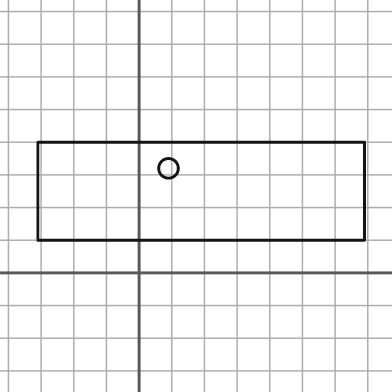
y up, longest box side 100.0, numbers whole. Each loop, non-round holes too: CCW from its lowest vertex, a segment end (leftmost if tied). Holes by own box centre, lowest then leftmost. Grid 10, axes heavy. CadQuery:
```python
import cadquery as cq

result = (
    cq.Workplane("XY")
    .moveTo(-31.0, 10.0)
    .lineTo(69.0, 10.0)
    .lineTo(69.0, 40.0)
    .lineTo(-31.0, 40.0)
    .close()
    .moveTo(9.0, 32.0)
    .circle(3.0)
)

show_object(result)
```